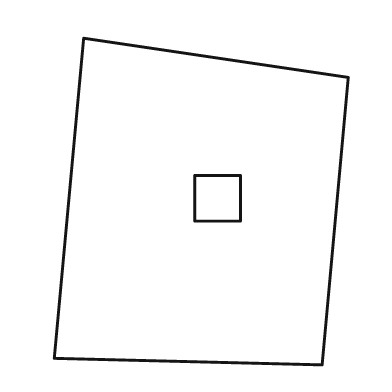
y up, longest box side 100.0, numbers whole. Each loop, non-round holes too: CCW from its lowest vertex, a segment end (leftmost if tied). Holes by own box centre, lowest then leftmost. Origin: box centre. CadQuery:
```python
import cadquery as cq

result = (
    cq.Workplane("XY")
    .moveTo(37.0, -50.0)
    .lineTo(45.0, 38.0)
    .lineTo(-36.0, 50.0)
    .lineTo(-45.0, -48.0)
    .close()
    .moveTo(-2.0, -6.0)
    .lineTo(12.0, -6.0)
    .lineTo(12.0, 8.0)
    .lineTo(-2.0, 8.0)
    .close()
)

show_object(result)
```